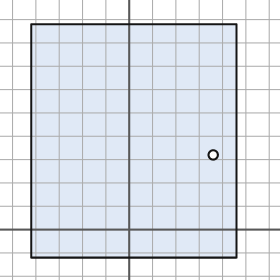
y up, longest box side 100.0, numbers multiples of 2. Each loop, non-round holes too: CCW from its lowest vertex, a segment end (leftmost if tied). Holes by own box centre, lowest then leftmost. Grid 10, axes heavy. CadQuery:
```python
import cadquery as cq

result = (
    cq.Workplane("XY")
    .moveTo(-42.0, -12.0)
    .lineTo(46.0, -12.0)
    .lineTo(46.0, 88.0)
    .lineTo(-42.0, 88.0)
    .close()
    .moveTo(36.0, 32.0)
    .circle(2.0)
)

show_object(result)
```